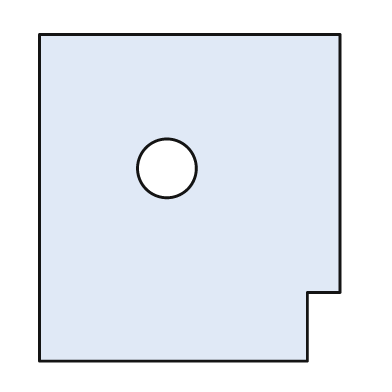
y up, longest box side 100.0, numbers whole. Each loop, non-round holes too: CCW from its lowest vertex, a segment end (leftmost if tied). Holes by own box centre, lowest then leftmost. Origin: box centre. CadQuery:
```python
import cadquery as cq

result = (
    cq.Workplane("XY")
    .moveTo(-46.0, -50.0)
    .lineTo(36.0, -50.0)
    .lineTo(36.0, -29.0)
    .lineTo(46.0, -29.0)
    .lineTo(46.0, 50.0)
    .lineTo(-46.0, 50.0)
    .close()
    .moveTo(-7.0, 9.0)
    .circle(9.0)
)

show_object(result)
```